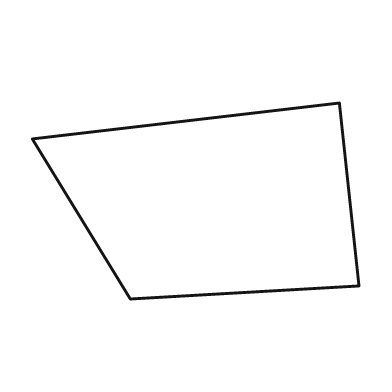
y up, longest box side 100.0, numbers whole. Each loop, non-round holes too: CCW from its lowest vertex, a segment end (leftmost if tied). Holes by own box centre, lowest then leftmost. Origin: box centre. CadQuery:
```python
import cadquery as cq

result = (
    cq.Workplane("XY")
    .moveTo(-20.0, -30.0)
    .lineTo(50.0, -26.0)
    .lineTo(44.0, 30.0)
    .lineTo(-50.0, 19.0)
    .close()
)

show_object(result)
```